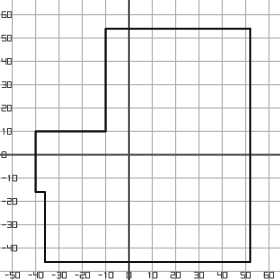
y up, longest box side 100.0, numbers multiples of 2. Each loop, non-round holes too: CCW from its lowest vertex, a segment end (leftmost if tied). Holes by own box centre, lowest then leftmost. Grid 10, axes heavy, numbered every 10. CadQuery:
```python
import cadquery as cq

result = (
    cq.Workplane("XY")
    .moveTo(-36.0, -46.0)
    .lineTo(52.0, -46.0)
    .lineTo(52.0, 54.0)
    .lineTo(-10.0, 54.0)
    .lineTo(-10.0, 10.0)
    .lineTo(-40.0, 10.0)
    .lineTo(-40.0, -16.0)
    .lineTo(-36.0, -16.0)
    .close()
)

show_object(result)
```